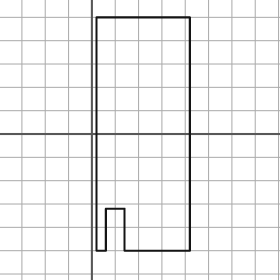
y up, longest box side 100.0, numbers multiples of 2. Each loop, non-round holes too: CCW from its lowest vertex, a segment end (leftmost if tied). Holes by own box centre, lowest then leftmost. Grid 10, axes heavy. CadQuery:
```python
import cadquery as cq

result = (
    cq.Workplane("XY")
    .moveTo(2.0, -50.0)
    .lineTo(6.0, -50.0)
    .lineTo(6.0, -32.0)
    .lineTo(14.0, -32.0)
    .lineTo(14.0, -50.0)
    .lineTo(42.0, -50.0)
    .lineTo(42.0, 50.0)
    .lineTo(2.0, 50.0)
    .close()
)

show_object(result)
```